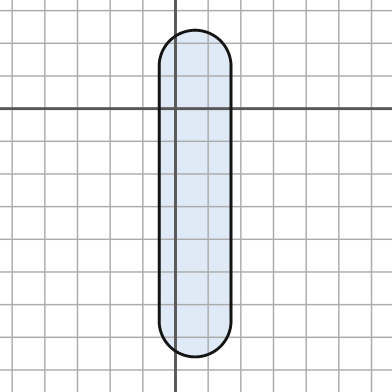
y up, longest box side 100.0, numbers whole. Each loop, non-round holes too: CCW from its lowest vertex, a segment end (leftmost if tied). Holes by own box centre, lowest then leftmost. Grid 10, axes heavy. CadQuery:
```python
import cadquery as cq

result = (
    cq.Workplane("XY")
    .moveTo(-5.0, -65.0)
    .threePointArc((6.0, -76.0), (17.0, -65.0))
    .lineTo(17.0, 13.0)
    .threePointArc((6.0, 24.0), (-5.0, 13.0))
    .close()
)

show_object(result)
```